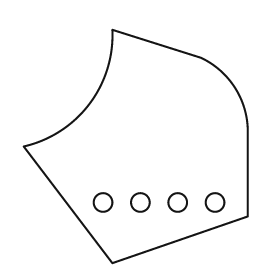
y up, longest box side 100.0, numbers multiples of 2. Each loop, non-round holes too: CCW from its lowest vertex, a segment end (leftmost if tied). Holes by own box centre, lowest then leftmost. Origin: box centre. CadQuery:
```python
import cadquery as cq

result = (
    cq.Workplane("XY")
    .moveTo(-10.0, -50.0)
    .lineTo(48.0, -30.0)
    .lineTo(48.0, 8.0)
    .threePointArc((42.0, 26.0), (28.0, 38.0))
    .lineTo(-10.0, 50.0)
    .threePointArc((-20.0, 18.0), (-48.0, 0.0))
    .close()
    .moveTo(-14.0, -24.0)
    .circle(4.0)
    .moveTo(2.0, -24.0)
    .circle(4.0)
    .moveTo(18.0, -24.0)
    .circle(4.0)
    .moveTo(34.0, -24.0)
    .circle(4.0)
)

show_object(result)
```